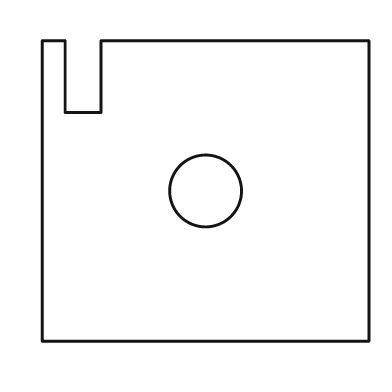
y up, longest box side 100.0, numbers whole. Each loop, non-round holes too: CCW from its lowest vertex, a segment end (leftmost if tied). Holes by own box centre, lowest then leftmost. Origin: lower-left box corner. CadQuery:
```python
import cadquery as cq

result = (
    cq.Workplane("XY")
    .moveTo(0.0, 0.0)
    .lineTo(100.0, 0.0)
    .lineTo(100.0, 92.0)
    .lineTo(18.0, 92.0)
    .lineTo(18.0, 70.0)
    .lineTo(7.0, 70.0)
    .lineTo(7.0, 92.0)
    .lineTo(0.0, 92.0)
    .close()
    .moveTo(50.0, 46.0)
    .circle(11.0)
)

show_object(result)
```